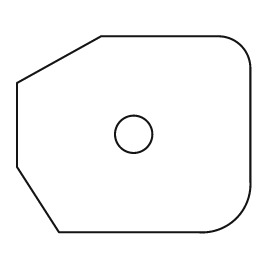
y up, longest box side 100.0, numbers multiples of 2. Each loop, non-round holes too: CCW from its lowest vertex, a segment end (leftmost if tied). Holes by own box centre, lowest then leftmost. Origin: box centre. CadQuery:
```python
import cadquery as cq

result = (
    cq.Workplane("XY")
    .moveTo(-32.0, -42.0)
    .lineTo(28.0, -42.0)
    .threePointArc((44.0, -36.0), (50.0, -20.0))
    .lineTo(50.0, 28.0)
    .threePointArc((46.0, 38.0), (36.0, 42.0))
    .lineTo(-14.0, 42.0)
    .lineTo(-50.0, 22.0)
    .lineTo(-50.0, -14.0)
    .close()
    .moveTo(0.0, 0.0)
    .circle(8.0)
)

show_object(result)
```